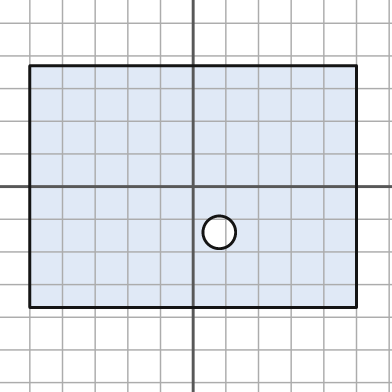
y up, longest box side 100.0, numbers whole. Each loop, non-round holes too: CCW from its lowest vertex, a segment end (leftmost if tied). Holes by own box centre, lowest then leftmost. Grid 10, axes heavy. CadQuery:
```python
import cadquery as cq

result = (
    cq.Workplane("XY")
    .moveTo(-50.0, -37.0)
    .lineTo(50.0, -37.0)
    .lineTo(50.0, 37.0)
    .lineTo(-50.0, 37.0)
    .close()
    .moveTo(8.0, -14.0)
    .circle(5.0)
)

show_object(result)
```